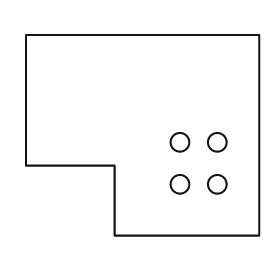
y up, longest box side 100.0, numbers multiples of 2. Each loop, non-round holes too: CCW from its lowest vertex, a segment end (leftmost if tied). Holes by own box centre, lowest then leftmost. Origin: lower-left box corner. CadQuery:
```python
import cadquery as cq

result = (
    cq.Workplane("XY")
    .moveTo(38.0, 0.0)
    .lineTo(100.0, 0.0)
    .lineTo(100.0, 86.0)
    .lineTo(0.0, 86.0)
    .lineTo(0.0, 30.0)
    .lineTo(38.0, 30.0)
    .close()
    .moveTo(66.0, 22.0)
    .circle(4.0)
    .moveTo(82.0, 22.0)
    .circle(4.0)
    .moveTo(66.0, 40.0)
    .circle(4.0)
    .moveTo(82.0, 40.0)
    .circle(4.0)
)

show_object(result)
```